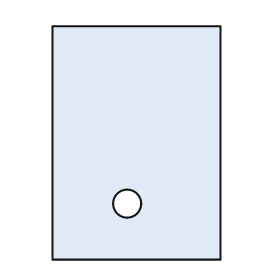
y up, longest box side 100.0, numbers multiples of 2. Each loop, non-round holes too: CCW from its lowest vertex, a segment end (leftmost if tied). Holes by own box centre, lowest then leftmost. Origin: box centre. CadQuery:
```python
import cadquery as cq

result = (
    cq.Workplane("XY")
    .moveTo(-36.0, -50.0)
    .lineTo(36.0, -50.0)
    .lineTo(36.0, 50.0)
    .lineTo(-36.0, 50.0)
    .close()
    .moveTo(-4.0, -26.0)
    .circle(6.0)
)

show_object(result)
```